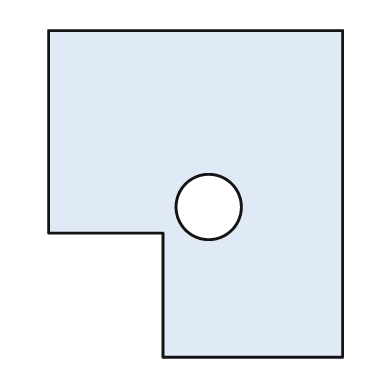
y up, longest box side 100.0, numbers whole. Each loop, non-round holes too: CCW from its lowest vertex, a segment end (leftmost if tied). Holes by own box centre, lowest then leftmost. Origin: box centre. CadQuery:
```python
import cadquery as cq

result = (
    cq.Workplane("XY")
    .moveTo(-10.0, -50.0)
    .lineTo(45.0, -50.0)
    .lineTo(45.0, 50.0)
    .lineTo(-45.0, 50.0)
    .lineTo(-45.0, -12.0)
    .lineTo(-10.0, -12.0)
    .close()
    .moveTo(4.0, -4.0)
    .circle(10.0)
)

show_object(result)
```